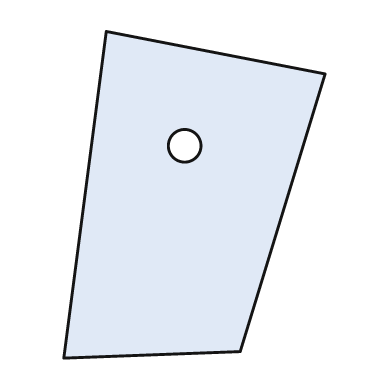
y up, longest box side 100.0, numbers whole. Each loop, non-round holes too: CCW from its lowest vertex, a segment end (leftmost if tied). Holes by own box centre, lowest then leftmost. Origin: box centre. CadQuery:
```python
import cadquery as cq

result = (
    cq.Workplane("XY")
    .moveTo(-40.0, -50.0)
    .lineTo(14.0, -48.0)
    .lineTo(40.0, 37.0)
    .lineTo(-27.0, 50.0)
    .close()
    .moveTo(-3.0, 15.0)
    .circle(5.0)
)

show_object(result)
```